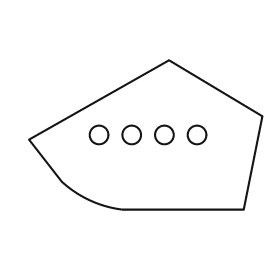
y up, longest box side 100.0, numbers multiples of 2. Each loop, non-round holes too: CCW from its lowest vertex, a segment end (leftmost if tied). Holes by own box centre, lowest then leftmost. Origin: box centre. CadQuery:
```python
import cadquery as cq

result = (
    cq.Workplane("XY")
    .moveTo(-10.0, -32.0)
    .lineTo(42.0, -32.0)
    .lineTo(50.0, 8.0)
    .lineTo(10.0, 32.0)
    .lineTo(-50.0, -2.0)
    .lineTo(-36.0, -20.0)
    .threePointArc((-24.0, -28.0), (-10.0, -32.0))
    .close()
    .moveTo(-20.0, 0.0)
    .circle(4.0)
    .moveTo(-6.0, 0.0)
    .circle(4.0)
    .moveTo(8.0, 0.0)
    .circle(4.0)
    .moveTo(22.0, 0.0)
    .circle(4.0)
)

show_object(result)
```